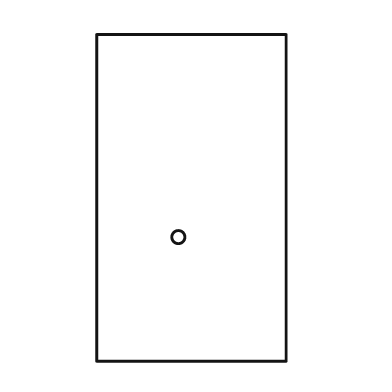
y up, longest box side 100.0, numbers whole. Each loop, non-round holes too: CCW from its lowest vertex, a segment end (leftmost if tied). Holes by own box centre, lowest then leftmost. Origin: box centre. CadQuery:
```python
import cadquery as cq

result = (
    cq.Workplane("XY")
    .moveTo(-29.0, -50.0)
    .lineTo(29.0, -50.0)
    .lineTo(29.0, 50.0)
    .lineTo(-29.0, 50.0)
    .close()
    .moveTo(-4.0, -12.0)
    .circle(2.0)
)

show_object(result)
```